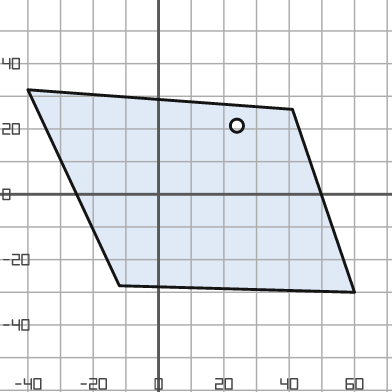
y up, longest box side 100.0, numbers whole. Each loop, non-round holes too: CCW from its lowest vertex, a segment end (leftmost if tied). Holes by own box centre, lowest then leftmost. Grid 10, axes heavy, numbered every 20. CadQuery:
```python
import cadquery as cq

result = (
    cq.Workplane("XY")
    .moveTo(60.0, -30.0)
    .lineTo(41.0, 26.0)
    .lineTo(-40.0, 32.0)
    .lineTo(-12.0, -28.0)
    .close()
    .moveTo(24.0, 21.0)
    .circle(2.0)
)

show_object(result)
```